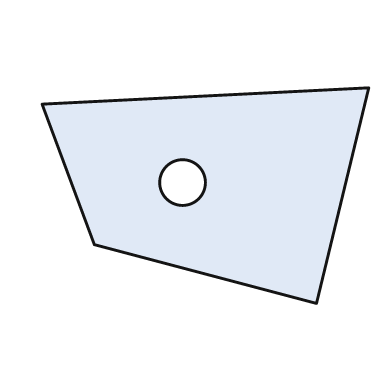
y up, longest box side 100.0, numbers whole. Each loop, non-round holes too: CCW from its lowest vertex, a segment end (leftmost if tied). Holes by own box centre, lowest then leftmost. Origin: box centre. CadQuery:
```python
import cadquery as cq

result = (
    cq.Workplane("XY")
    .moveTo(34.0, -33.0)
    .lineTo(50.0, 33.0)
    .lineTo(-50.0, 28.0)
    .lineTo(-34.0, -15.0)
    .close()
    .moveTo(-7.0, 4.0)
    .circle(7.0)
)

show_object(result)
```